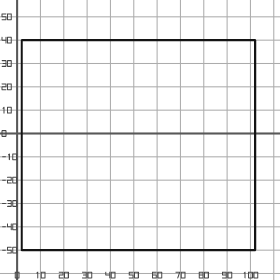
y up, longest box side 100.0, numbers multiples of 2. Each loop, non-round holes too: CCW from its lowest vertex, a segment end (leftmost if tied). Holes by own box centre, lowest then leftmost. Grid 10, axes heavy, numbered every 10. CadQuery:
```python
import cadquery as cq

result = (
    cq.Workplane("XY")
    .moveTo(2.0, -50.0)
    .lineTo(102.0, -50.0)
    .lineTo(102.0, 40.0)
    .lineTo(2.0, 40.0)
    .close()
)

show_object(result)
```